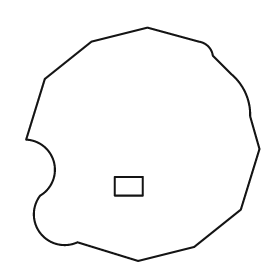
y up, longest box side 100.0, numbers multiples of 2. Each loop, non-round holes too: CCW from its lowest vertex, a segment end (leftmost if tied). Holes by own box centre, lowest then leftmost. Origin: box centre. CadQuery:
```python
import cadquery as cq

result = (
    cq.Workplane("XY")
    .moveTo(-2.0, -50.0)
    .lineTo(22.0, -44.0)
    .lineTo(42.0, -28.0)
    .lineTo(50.0, -2.0)
    .lineTo(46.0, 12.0)
    .threePointArc((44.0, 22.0), (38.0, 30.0))
    .lineTo(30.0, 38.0)
    .threePointArc((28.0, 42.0), (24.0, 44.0))
    .lineTo(2.0, 50.0)
    .lineTo(-22.0, 44.0)
    .lineTo(-42.0, 28.0)
    .lineTo(-50.0, 2.0)
    .threePointArc((-38.0, -8.0), (-44.0, -22.0))
    .threePointArc((-44.0, -38.0), (-28.0, -42.0))
    .close()
    .moveTo(-12.0, -22.0)
    .lineTo(0.0, -22.0)
    .lineTo(0.0, -14.0)
    .lineTo(-12.0, -14.0)
    .close()
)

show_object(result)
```